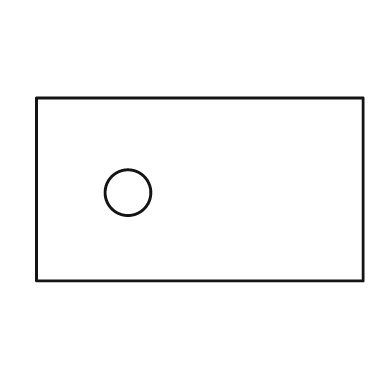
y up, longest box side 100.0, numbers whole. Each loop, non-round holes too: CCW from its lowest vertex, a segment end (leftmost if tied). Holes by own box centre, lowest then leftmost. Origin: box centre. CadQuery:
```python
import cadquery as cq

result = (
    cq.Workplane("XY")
    .moveTo(-50.0, -28.0)
    .lineTo(50.0, -28.0)
    .lineTo(50.0, 28.0)
    .lineTo(-50.0, 28.0)
    .close()
    .moveTo(-22.0, -1.0)
    .circle(7.0)
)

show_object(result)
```